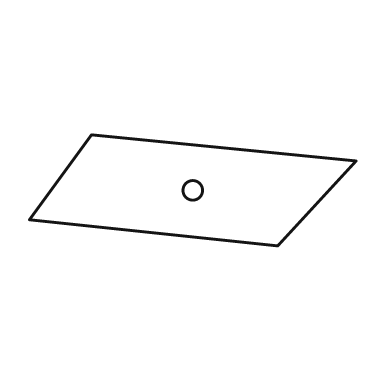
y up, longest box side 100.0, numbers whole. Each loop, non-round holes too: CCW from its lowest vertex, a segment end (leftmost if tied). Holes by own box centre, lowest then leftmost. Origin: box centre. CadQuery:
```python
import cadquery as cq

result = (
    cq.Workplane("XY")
    .moveTo(26.0, -17.0)
    .lineTo(50.0, 9.0)
    .lineTo(-31.0, 17.0)
    .lineTo(-50.0, -9.0)
    .close()
    .moveTo(0.0, 0.0)
    .circle(3.0)
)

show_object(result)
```